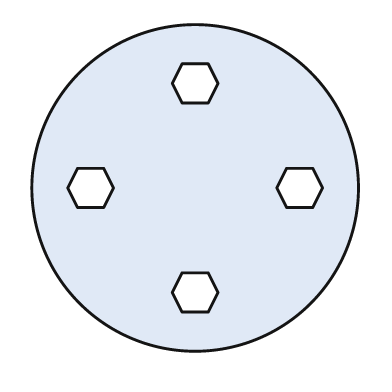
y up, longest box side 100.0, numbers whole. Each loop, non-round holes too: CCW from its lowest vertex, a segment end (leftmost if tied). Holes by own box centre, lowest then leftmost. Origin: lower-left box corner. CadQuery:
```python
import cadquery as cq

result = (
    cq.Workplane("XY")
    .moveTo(50.0, 50.0)
    .circle(50.0)
    .moveTo(46.0, 12.0)
    .lineTo(54.0, 12.0)
    .lineTo(57.0, 18.0)
    .lineTo(54.0, 24.0)
    .lineTo(46.0, 24.0)
    .lineTo(43.0, 18.0)
    .close()
    .moveTo(14.0, 44.0)
    .lineTo(22.0, 44.0)
    .lineTo(25.0, 50.0)
    .lineTo(22.0, 56.0)
    .lineTo(14.0, 56.0)
    .lineTo(11.0, 50.0)
    .close()
    .moveTo(78.0, 44.0)
    .lineTo(86.0, 44.0)
    .lineTo(89.0, 50.0)
    .lineTo(86.0, 56.0)
    .lineTo(78.0, 56.0)
    .lineTo(75.0, 50.0)
    .close()
    .moveTo(46.0, 76.0)
    .lineTo(54.0, 76.0)
    .lineTo(57.0, 82.0)
    .lineTo(54.0, 88.0)
    .lineTo(46.0, 88.0)
    .lineTo(43.0, 82.0)
    .close()
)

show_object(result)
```